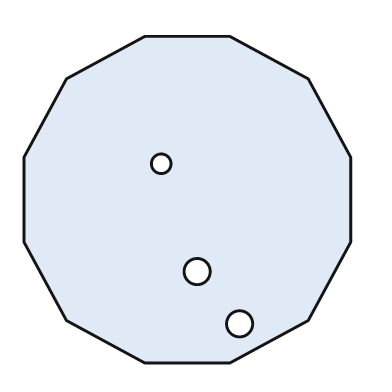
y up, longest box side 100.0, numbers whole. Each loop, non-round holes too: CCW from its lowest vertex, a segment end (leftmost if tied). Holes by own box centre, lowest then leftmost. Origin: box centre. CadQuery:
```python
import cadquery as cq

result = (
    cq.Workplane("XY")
    .moveTo(-13.0, -50.0)
    .lineTo(13.0, -50.0)
    .lineTo(37.0, -37.0)
    .lineTo(50.0, -13.0)
    .lineTo(50.0, 13.0)
    .lineTo(37.0, 37.0)
    .lineTo(13.0, 50.0)
    .lineTo(-13.0, 50.0)
    .lineTo(-37.0, 37.0)
    .lineTo(-50.0, 13.0)
    .lineTo(-50.0, -13.0)
    .lineTo(-37.0, -37.0)
    .close()
    .moveTo(16.0, -38.0)
    .circle(4.0)
    .moveTo(3.0, -22.0)
    .circle(4.0)
    .moveTo(-8.0, 11.0)
    .circle(3.0)
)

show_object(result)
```